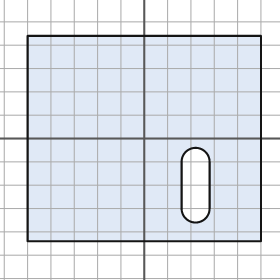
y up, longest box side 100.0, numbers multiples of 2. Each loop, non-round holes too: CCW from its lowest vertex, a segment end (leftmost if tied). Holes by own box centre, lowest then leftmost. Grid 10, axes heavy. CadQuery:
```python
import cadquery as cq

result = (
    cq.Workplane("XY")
    .moveTo(-50.0, -44.0)
    .lineTo(50.0, -44.0)
    .lineTo(50.0, 44.0)
    .lineTo(-50.0, 44.0)
    .close()
    .moveTo(16.0, -30.0)
    .threePointArc((22.0, -36.0), (28.0, -30.0))
    .lineTo(28.0, -10.0)
    .threePointArc((22.0, -4.0), (16.0, -10.0))
    .close()
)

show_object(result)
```